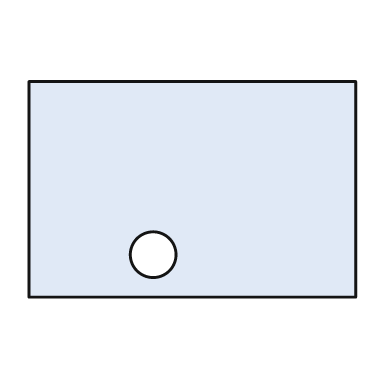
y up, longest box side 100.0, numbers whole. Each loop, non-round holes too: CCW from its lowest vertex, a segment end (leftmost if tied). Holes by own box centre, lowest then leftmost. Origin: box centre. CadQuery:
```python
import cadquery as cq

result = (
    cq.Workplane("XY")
    .moveTo(-50.0, -33.0)
    .lineTo(50.0, -33.0)
    .lineTo(50.0, 33.0)
    .lineTo(-50.0, 33.0)
    .close()
    .moveTo(-12.0, -20.0)
    .circle(7.0)
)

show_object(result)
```